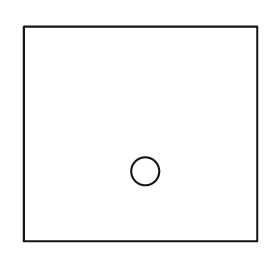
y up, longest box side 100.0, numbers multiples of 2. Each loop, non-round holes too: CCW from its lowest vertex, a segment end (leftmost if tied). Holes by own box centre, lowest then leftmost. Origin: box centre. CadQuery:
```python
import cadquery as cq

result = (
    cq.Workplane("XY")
    .moveTo(-50.0, -46.0)
    .lineTo(50.0, -46.0)
    .lineTo(50.0, 46.0)
    .lineTo(-50.0, 46.0)
    .close()
    .moveTo(2.0, -16.0)
    .circle(6.0)
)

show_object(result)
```